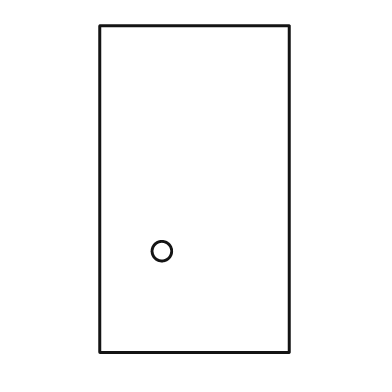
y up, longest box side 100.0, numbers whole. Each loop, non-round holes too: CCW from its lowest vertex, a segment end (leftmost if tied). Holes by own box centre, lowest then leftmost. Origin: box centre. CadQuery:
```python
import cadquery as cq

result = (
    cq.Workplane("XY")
    .moveTo(-29.0, -50.0)
    .lineTo(29.0, -50.0)
    .lineTo(29.0, 50.0)
    .lineTo(-29.0, 50.0)
    .close()
    .moveTo(-10.0, -19.0)
    .circle(3.0)
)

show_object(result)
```